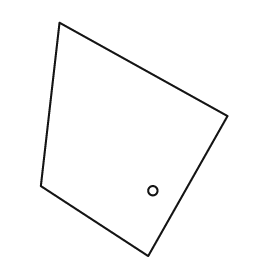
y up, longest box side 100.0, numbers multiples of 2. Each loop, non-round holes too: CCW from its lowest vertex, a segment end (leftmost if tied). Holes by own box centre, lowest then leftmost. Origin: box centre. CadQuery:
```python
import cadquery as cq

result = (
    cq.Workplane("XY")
    .moveTo(6.0, -50.0)
    .lineTo(40.0, 10.0)
    .lineTo(-32.0, 50.0)
    .lineTo(-40.0, -20.0)
    .close()
    .moveTo(8.0, -22.0)
    .circle(2.0)
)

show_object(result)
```